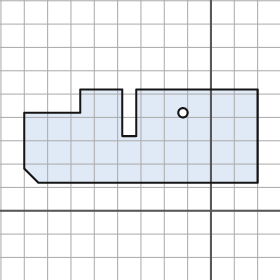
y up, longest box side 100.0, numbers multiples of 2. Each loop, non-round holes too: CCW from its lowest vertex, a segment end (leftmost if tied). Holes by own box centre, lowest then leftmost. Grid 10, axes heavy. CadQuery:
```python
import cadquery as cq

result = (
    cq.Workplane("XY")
    .moveTo(-74.0, 12.0)
    .lineTo(20.0, 12.0)
    .lineTo(20.0, 52.0)
    .lineTo(-32.0, 52.0)
    .lineTo(-32.0, 32.0)
    .lineTo(-38.0, 32.0)
    .lineTo(-38.0, 52.0)
    .lineTo(-56.0, 52.0)
    .lineTo(-56.0, 42.0)
    .lineTo(-80.0, 42.0)
    .lineTo(-80.0, 18.0)
    .close()
    .moveTo(-12.0, 42.0)
    .circle(2.0)
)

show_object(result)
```